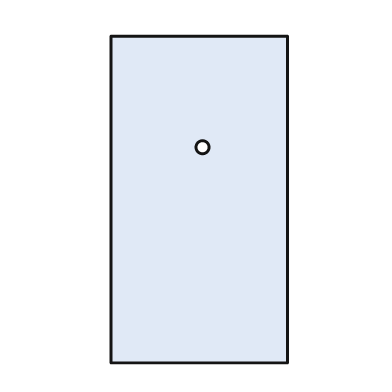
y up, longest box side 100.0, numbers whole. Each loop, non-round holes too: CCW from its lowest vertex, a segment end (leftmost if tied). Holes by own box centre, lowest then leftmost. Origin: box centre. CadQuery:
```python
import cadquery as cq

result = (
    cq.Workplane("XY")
    .moveTo(-27.0, -50.0)
    .lineTo(27.0, -50.0)
    .lineTo(27.0, 50.0)
    .lineTo(-27.0, 50.0)
    .close()
    .moveTo(1.0, 16.0)
    .circle(2.0)
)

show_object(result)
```